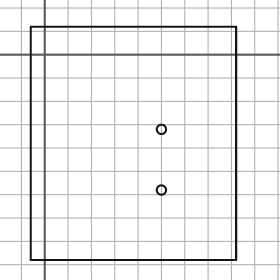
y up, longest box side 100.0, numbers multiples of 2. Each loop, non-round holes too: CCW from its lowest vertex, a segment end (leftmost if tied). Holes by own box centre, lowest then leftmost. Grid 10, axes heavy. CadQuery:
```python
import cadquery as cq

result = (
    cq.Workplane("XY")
    .moveTo(-6.0, -88.0)
    .lineTo(82.0, -88.0)
    .lineTo(82.0, 12.0)
    .lineTo(-6.0, 12.0)
    .close()
    .moveTo(50.0, -58.0)
    .circle(2.0)
    .moveTo(50.0, -32.0)
    .circle(2.0)
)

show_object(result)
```